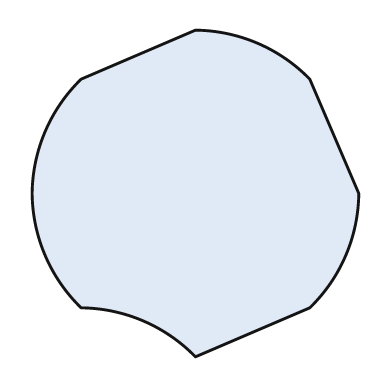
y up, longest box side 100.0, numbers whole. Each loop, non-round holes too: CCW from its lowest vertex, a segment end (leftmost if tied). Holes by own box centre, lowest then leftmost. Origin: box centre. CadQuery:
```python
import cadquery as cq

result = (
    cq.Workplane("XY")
    .moveTo(0.0, -50.0)
    .lineTo(35.0, -35.0)
    .threePointArc((46.0, -19.0), (50.0, 0.0))
    .lineTo(35.0, 35.0)
    .threePointArc((19.0, 46.0), (0.0, 50.0))
    .lineTo(-35.0, 35.0)
    .threePointArc((-46.0, 19.0), (-50.0, 0.0))
    .threePointArc((-46.0, -19.0), (-35.0, -35.0))
    .threePointArc((-16.0, -39.0), (0.0, -50.0))
    .close()
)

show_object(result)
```